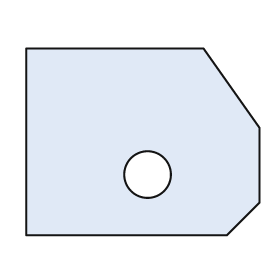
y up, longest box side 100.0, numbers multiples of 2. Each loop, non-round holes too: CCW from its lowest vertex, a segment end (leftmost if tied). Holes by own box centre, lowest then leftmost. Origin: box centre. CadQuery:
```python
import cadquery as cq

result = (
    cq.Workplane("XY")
    .moveTo(-50.0, -40.0)
    .lineTo(36.0, -40.0)
    .lineTo(50.0, -26.0)
    .lineTo(50.0, 6.0)
    .lineTo(26.0, 40.0)
    .lineTo(-50.0, 40.0)
    .close()
    .moveTo(2.0, -14.0)
    .circle(10.0)
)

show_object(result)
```